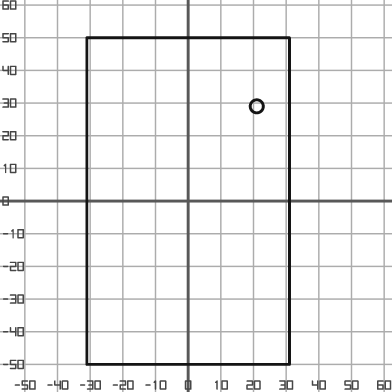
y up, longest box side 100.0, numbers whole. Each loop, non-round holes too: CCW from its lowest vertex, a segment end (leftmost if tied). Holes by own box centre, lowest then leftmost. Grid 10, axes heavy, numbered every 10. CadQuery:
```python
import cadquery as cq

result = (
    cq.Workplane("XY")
    .moveTo(-31.0, -50.0)
    .lineTo(31.0, -50.0)
    .lineTo(31.0, 50.0)
    .lineTo(-31.0, 50.0)
    .close()
    .moveTo(21.0, 29.0)
    .circle(2.0)
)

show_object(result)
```